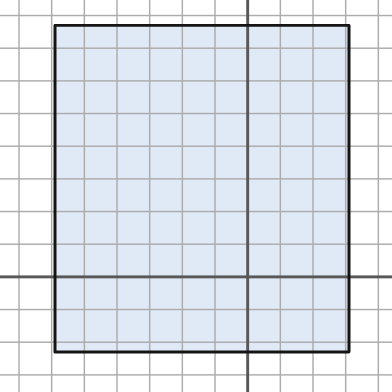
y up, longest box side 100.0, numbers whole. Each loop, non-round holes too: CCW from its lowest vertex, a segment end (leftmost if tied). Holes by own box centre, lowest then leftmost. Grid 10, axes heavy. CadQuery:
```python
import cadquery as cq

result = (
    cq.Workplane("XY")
    .moveTo(-59.0, -23.0)
    .lineTo(31.0, -23.0)
    .lineTo(31.0, 77.0)
    .lineTo(-59.0, 77.0)
    .close()
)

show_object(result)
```